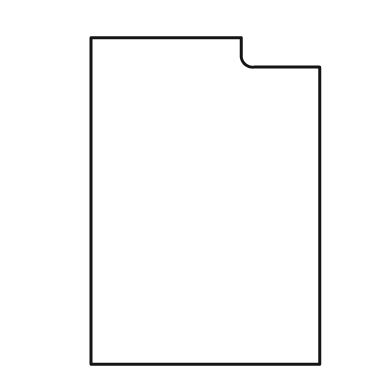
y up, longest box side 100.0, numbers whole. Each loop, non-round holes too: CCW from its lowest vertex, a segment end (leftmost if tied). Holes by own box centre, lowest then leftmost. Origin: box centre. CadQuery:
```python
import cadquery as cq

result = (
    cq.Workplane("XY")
    .moveTo(-35.0, -50.0)
    .lineTo(35.0, -50.0)
    .lineTo(35.0, 41.0)
    .lineTo(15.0, 41.0)
    .threePointArc((12.0, 42.0), (11.0, 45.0))
    .lineTo(11.0, 50.0)
    .lineTo(-35.0, 50.0)
    .close()
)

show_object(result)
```